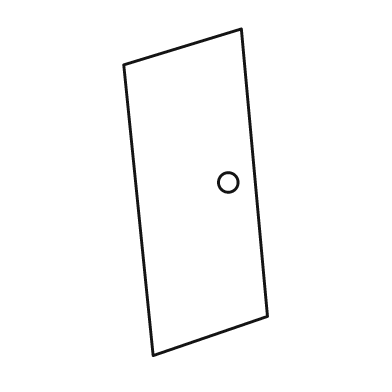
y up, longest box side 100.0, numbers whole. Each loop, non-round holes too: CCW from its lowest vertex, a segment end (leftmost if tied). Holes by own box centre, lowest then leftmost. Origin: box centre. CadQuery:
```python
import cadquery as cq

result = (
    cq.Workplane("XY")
    .moveTo(-13.0, -50.0)
    .lineTo(22.0, -38.0)
    .lineTo(14.0, 50.0)
    .lineTo(-22.0, 39.0)
    .close()
    .moveTo(10.0, 3.0)
    .circle(3.0)
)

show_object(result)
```